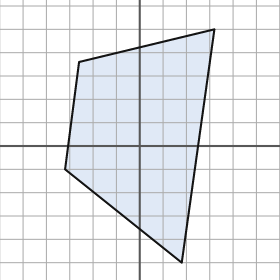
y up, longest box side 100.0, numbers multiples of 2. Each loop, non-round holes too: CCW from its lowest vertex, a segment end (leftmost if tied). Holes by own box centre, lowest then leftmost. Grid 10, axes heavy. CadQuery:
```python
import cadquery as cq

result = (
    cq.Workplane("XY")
    .moveTo(18.0, -50.0)
    .lineTo(32.0, 50.0)
    .lineTo(-26.0, 36.0)
    .lineTo(-32.0, -10.0)
    .close()
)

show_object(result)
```